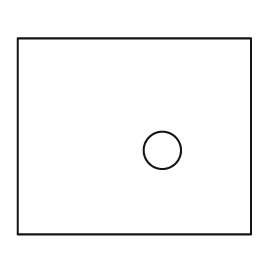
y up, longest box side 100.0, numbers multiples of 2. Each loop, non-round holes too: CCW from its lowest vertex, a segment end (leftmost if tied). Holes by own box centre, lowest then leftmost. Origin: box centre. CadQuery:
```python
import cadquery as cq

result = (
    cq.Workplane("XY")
    .moveTo(-50.0, -42.0)
    .lineTo(50.0, -42.0)
    .lineTo(50.0, 42.0)
    .lineTo(-50.0, 42.0)
    .close()
    .moveTo(12.0, -6.0)
    .circle(8.0)
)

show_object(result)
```